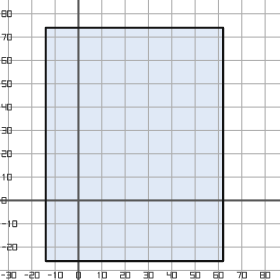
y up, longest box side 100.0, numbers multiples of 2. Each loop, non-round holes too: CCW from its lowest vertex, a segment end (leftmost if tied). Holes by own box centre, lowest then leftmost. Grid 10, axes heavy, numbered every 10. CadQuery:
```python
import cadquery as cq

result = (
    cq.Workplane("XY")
    .moveTo(-14.0, -26.0)
    .lineTo(62.0, -26.0)
    .lineTo(62.0, 74.0)
    .lineTo(-14.0, 74.0)
    .close()
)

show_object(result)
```